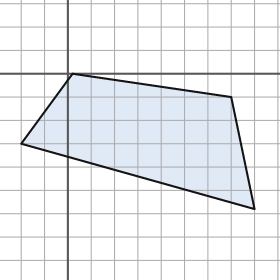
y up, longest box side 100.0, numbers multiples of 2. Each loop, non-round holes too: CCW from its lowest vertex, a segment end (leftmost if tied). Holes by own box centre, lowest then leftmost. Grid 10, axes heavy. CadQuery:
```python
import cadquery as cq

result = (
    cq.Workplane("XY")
    .moveTo(80.0, -58.0)
    .lineTo(70.0, -10.0)
    .lineTo(2.0, 0.0)
    .lineTo(-20.0, -30.0)
    .close()
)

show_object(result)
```